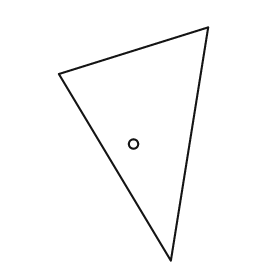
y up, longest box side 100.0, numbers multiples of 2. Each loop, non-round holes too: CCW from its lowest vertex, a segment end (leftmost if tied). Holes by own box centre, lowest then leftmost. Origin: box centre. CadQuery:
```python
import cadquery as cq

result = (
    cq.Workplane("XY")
    .moveTo(16.0, -50.0)
    .lineTo(32.0, 50.0)
    .lineTo(-32.0, 30.0)
    .close()
    .moveTo(0.0, 0.0)
    .circle(2.0)
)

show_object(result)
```